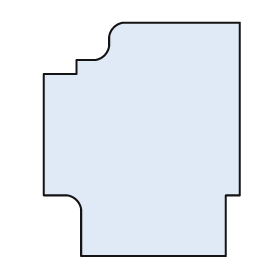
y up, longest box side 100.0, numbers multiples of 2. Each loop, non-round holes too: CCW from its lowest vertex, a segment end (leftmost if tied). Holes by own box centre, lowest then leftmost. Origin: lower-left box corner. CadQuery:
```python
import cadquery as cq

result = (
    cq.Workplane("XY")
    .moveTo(16.0, 0.0)
    .lineTo(78.0, 0.0)
    .lineTo(78.0, 26.0)
    .lineTo(84.0, 26.0)
    .lineTo(84.0, 100.0)
    .lineTo(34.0, 100.0)
    .threePointArc((30.0, 98.0), (28.0, 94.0))
    .lineTo(28.0, 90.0)
    .threePointArc((26.0, 86.0), (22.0, 84.0))
    .lineTo(14.0, 84.0)
    .lineTo(14.0, 78.0)
    .lineTo(0.0, 78.0)
    .lineTo(0.0, 26.0)
    .lineTo(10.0, 26.0)
    .threePointArc((14.0, 24.0), (16.0, 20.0))
    .close()
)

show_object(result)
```